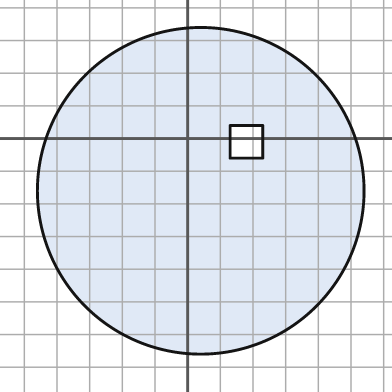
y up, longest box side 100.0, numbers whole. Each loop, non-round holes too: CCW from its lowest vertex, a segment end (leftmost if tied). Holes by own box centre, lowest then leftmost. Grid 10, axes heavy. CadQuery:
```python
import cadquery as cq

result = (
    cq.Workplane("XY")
    .moveTo(4.0, -16.0)
    .circle(50.0)
    .moveTo(13.0, -6.0)
    .lineTo(23.0, -6.0)
    .lineTo(23.0, 4.0)
    .lineTo(13.0, 4.0)
    .close()
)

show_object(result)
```